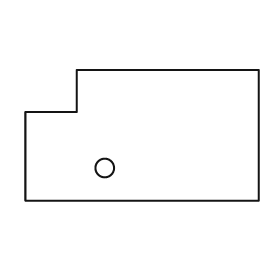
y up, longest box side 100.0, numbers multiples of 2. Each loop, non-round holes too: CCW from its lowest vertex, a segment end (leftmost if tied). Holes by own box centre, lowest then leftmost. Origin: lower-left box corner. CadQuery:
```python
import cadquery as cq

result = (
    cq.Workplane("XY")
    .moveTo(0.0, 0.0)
    .lineTo(100.0, 0.0)
    .lineTo(100.0, 56.0)
    .lineTo(22.0, 56.0)
    .lineTo(22.0, 38.0)
    .lineTo(0.0, 38.0)
    .close()
    .moveTo(34.0, 14.0)
    .circle(4.0)
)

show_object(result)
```